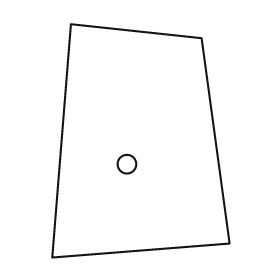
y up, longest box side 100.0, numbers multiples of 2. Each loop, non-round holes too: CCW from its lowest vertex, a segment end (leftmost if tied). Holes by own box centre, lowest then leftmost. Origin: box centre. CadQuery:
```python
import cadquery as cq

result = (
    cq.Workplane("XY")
    .moveTo(-38.0, -50.0)
    .lineTo(38.0, -44.0)
    .lineTo(26.0, 44.0)
    .lineTo(-30.0, 50.0)
    .close()
    .moveTo(-6.0, -10.0)
    .circle(4.0)
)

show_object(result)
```